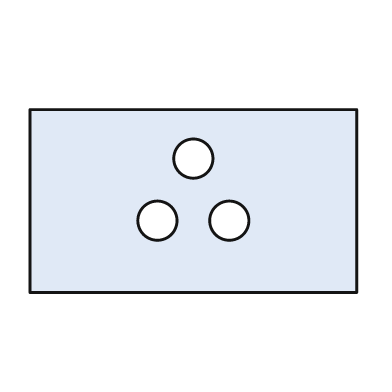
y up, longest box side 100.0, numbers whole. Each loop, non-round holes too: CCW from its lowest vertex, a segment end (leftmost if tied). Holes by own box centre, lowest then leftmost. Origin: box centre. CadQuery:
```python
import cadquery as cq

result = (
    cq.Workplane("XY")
    .moveTo(-50.0, -28.0)
    .lineTo(50.0, -28.0)
    .lineTo(50.0, 28.0)
    .lineTo(-50.0, 28.0)
    .close()
    .moveTo(-11.0, -6.0)
    .circle(6.0)
    .moveTo(11.0, -6.0)
    .circle(6.0)
    .moveTo(0.0, 13.0)
    .circle(6.0)
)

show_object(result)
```